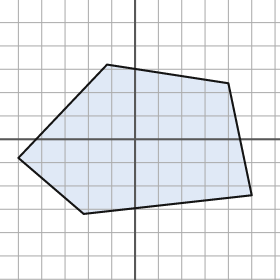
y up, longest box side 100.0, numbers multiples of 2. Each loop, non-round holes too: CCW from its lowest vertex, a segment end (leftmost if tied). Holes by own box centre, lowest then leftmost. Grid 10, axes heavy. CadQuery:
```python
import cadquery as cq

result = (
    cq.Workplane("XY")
    .moveTo(-22.0, -32.0)
    .lineTo(50.0, -24.0)
    .lineTo(40.0, 24.0)
    .lineTo(-12.0, 32.0)
    .lineTo(-50.0, -8.0)
    .close()
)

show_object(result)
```